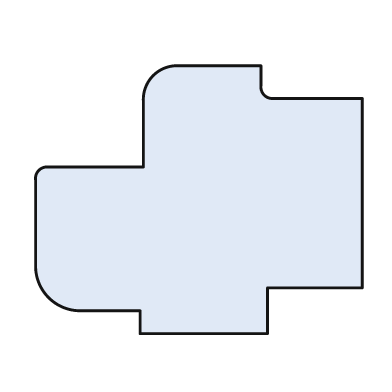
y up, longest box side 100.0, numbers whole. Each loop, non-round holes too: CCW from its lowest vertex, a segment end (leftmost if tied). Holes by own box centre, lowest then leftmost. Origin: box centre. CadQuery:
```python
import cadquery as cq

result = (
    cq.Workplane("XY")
    .moveTo(-18.0, -41.0)
    .lineTo(21.0, -41.0)
    .lineTo(21.0, -27.0)
    .lineTo(50.0, -27.0)
    .lineTo(50.0, 31.0)
    .lineTo(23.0, 31.0)
    .threePointArc((20.0, 32.0), (19.0, 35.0))
    .lineTo(19.0, 41.0)
    .lineTo(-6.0, 41.0)
    .threePointArc((-14.0, 38.0), (-17.0, 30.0))
    .lineTo(-17.0, 10.0)
    .lineTo(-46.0, 10.0)
    .threePointArc((-49.0, 9.0), (-50.0, 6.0))
    .lineTo(-50.0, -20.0)
    .threePointArc((-46.0, -30.0), (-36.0, -34.0))
    .lineTo(-18.0, -34.0)
    .close()
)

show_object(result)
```